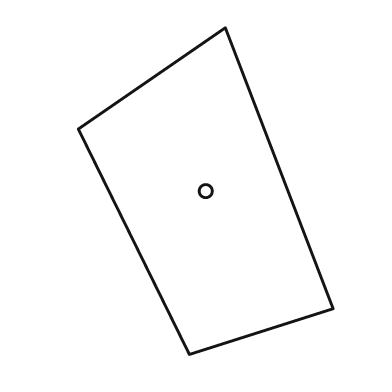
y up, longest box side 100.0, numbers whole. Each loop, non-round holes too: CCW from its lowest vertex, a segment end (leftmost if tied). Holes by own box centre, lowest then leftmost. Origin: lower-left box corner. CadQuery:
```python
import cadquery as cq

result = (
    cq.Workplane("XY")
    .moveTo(34.0, 0.0)
    .lineTo(78.0, 14.0)
    .lineTo(45.0, 100.0)
    .lineTo(0.0, 69.0)
    .close()
    .moveTo(39.0, 50.0)
    .circle(2.0)
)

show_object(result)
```